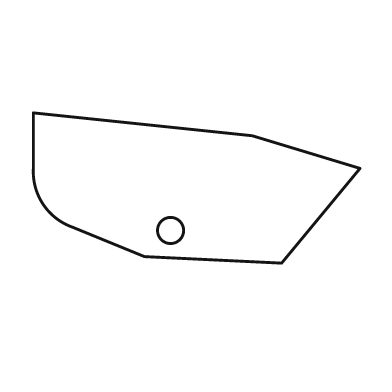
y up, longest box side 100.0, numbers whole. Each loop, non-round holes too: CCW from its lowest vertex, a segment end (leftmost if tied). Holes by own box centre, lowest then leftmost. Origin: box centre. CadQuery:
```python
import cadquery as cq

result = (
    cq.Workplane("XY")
    .moveTo(26.0, -23.0)
    .lineTo(50.0, 6.0)
    .lineTo(17.0, 16.0)
    .lineTo(-50.0, 23.0)
    .lineTo(-50.0, 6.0)
    .threePointArc((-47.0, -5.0), (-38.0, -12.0))
    .lineTo(-16.0, -21.0)
    .close()
    .moveTo(-8.0, -13.0)
    .circle(4.0)
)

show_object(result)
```